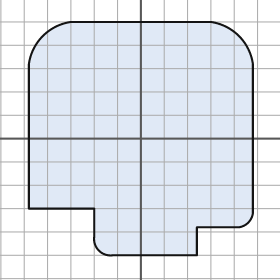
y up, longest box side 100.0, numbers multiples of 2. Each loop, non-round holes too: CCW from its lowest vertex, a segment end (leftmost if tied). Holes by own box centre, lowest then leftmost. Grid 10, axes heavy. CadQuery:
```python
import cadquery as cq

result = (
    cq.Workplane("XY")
    .moveTo(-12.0, -50.0)
    .lineTo(24.0, -50.0)
    .lineTo(24.0, -38.0)
    .lineTo(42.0, -38.0)
    .threePointArc((46.0, -36.0), (48.0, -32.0))
    .lineTo(48.0, 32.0)
    .threePointArc((42.0, 44.0), (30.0, 50.0))
    .lineTo(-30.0, 50.0)
    .threePointArc((-42.0, 44.0), (-48.0, 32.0))
    .lineTo(-48.0, -30.0)
    .lineTo(-20.0, -30.0)
    .lineTo(-20.0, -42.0)
    .threePointArc((-18.0, -48.0), (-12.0, -50.0))
    .close()
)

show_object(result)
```